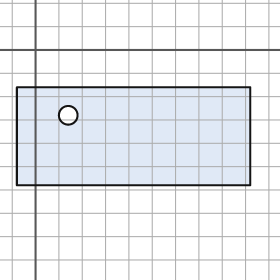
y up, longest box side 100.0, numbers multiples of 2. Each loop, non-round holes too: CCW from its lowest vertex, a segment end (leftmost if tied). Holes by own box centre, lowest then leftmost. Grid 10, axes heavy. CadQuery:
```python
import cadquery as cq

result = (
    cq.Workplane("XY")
    .moveTo(-8.0, -58.0)
    .lineTo(92.0, -58.0)
    .lineTo(92.0, -16.0)
    .lineTo(-8.0, -16.0)
    .close()
    .moveTo(14.0, -28.0)
    .circle(4.0)
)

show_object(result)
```